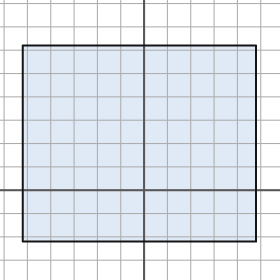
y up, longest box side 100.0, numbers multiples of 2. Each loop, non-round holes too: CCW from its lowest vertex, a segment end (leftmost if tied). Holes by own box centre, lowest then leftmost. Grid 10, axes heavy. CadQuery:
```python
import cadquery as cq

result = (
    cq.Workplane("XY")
    .moveTo(-52.0, -22.0)
    .lineTo(48.0, -22.0)
    .lineTo(48.0, 62.0)
    .lineTo(-52.0, 62.0)
    .close()
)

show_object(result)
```